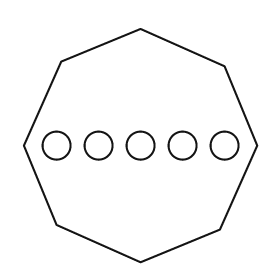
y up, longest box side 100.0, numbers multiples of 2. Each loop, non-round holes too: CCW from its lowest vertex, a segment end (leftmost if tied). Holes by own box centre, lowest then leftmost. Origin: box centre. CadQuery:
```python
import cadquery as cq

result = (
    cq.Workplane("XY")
    .moveTo(0.0, -50.0)
    .lineTo(34.0, -36.0)
    .lineTo(50.0, 0.0)
    .lineTo(36.0, 34.0)
    .lineTo(0.0, 50.0)
    .lineTo(-34.0, 36.0)
    .lineTo(-50.0, 0.0)
    .lineTo(-36.0, -34.0)
    .close()
    .moveTo(-36.0, 0.0)
    .circle(6.0)
    .moveTo(-18.0, 0.0)
    .circle(6.0)
    .moveTo(0.0, 0.0)
    .circle(6.0)
    .moveTo(18.0, 0.0)
    .circle(6.0)
    .moveTo(36.0, 0.0)
    .circle(6.0)
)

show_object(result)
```